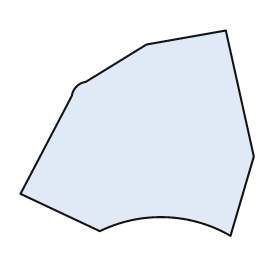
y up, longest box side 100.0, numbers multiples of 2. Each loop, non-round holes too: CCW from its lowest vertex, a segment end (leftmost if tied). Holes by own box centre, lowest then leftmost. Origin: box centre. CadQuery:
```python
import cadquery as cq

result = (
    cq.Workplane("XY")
    .moveTo(40.0, -44.0)
    .lineTo(50.0, -10.0)
    .lineTo(38.0, 44.0)
    .lineTo(4.0, 38.0)
    .lineTo(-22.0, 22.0)
    .threePointArc((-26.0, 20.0), (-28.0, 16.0))
    .lineTo(-50.0, -26.0)
    .lineTo(-16.0, -42.0)
    .threePointArc((12.0, -36.0), (40.0, -44.0))
    .close()
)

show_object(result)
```